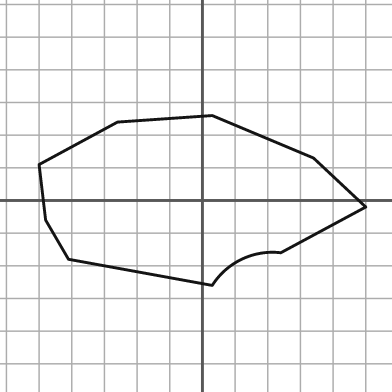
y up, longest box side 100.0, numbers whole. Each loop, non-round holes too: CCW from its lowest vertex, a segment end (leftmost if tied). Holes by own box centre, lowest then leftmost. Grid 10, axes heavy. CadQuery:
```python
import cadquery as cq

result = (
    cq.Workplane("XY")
    .moveTo(3.0, -26.0)
    .threePointArc((12.0, -18.0), (24.0, -16.0))
    .lineTo(50.0, -2.0)
    .lineTo(34.0, 13.0)
    .lineTo(3.0, 26.0)
    .lineTo(-26.0, 24.0)
    .lineTo(-50.0, 11.0)
    .lineTo(-48.0, -6.0)
    .lineTo(-41.0, -18.0)
    .close()
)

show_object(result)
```